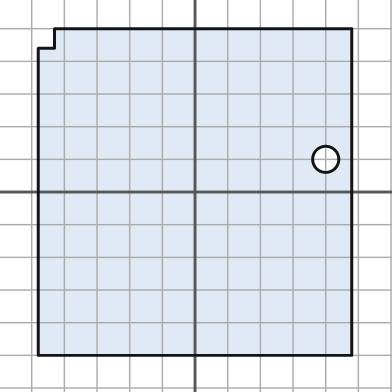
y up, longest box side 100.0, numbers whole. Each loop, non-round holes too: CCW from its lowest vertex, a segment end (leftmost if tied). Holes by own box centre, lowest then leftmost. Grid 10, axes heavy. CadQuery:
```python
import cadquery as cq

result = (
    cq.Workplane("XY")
    .moveTo(-48.0, -50.0)
    .lineTo(48.0, -50.0)
    .lineTo(48.0, 50.0)
    .lineTo(-43.0, 50.0)
    .lineTo(-43.0, 44.0)
    .lineTo(-48.0, 44.0)
    .close()
    .moveTo(40.0, 10.0)
    .circle(4.0)
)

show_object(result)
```